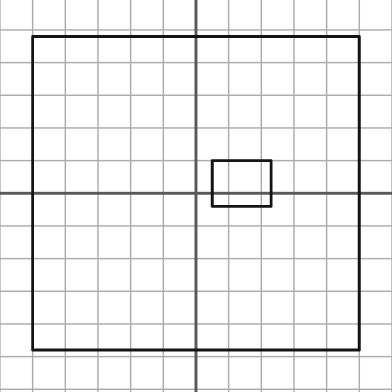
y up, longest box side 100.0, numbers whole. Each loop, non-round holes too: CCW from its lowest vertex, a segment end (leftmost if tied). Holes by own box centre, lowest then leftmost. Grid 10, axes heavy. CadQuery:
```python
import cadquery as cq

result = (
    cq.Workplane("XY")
    .moveTo(-50.0, -48.0)
    .lineTo(50.0, -48.0)
    .lineTo(50.0, 48.0)
    .lineTo(-50.0, 48.0)
    .close()
    .moveTo(5.0, -4.0)
    .lineTo(23.0, -4.0)
    .lineTo(23.0, 10.0)
    .lineTo(5.0, 10.0)
    .close()
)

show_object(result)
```